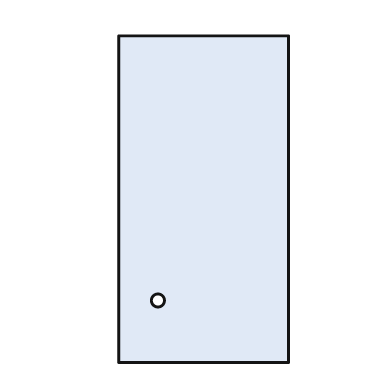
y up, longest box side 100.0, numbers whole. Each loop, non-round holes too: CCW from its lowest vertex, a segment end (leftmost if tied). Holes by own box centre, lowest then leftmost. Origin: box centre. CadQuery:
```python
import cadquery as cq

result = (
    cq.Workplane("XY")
    .moveTo(-26.0, -50.0)
    .lineTo(26.0, -50.0)
    .lineTo(26.0, 50.0)
    .lineTo(-26.0, 50.0)
    .close()
    .moveTo(-14.0, -31.0)
    .circle(2.0)
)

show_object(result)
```